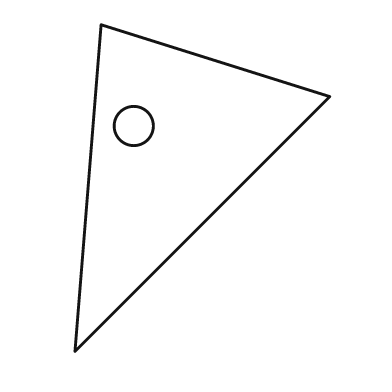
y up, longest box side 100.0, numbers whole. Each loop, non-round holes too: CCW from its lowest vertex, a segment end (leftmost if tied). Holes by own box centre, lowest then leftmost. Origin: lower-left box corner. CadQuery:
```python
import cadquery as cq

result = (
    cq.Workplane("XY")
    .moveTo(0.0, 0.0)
    .lineTo(78.0, 78.0)
    .lineTo(8.0, 100.0)
    .close()
    .moveTo(18.0, 69.0)
    .circle(6.0)
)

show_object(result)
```